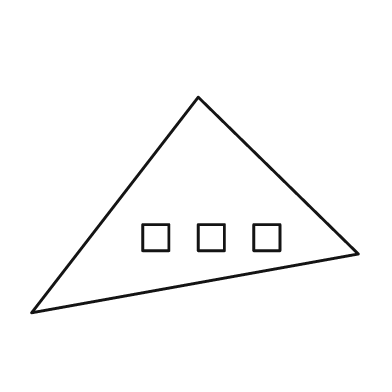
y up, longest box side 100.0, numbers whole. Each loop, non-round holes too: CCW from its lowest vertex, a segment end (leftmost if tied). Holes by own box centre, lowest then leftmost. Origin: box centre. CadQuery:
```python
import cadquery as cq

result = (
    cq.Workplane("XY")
    .moveTo(-50.0, -33.0)
    .lineTo(50.0, -15.0)
    .lineTo(1.0, 33.0)
    .close()
    .moveTo(-16.0, -14.0)
    .lineTo(-8.0, -14.0)
    .lineTo(-8.0, -6.0)
    .lineTo(-16.0, -6.0)
    .close()
    .moveTo(1.0, -14.0)
    .lineTo(9.0, -14.0)
    .lineTo(9.0, -6.0)
    .lineTo(1.0, -6.0)
    .close()
    .moveTo(18.0, -14.0)
    .lineTo(26.0, -14.0)
    .lineTo(26.0, -6.0)
    .lineTo(18.0, -6.0)
    .close()
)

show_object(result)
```